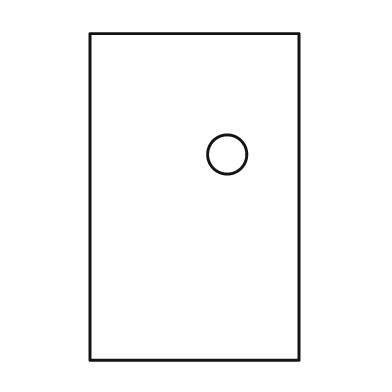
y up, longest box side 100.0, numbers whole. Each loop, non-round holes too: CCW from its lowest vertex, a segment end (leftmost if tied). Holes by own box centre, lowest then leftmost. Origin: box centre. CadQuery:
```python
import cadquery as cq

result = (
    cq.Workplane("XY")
    .moveTo(-32.0, -50.0)
    .lineTo(32.0, -50.0)
    .lineTo(32.0, 50.0)
    .lineTo(-32.0, 50.0)
    .close()
    .moveTo(10.0, 13.0)
    .circle(6.0)
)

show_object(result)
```